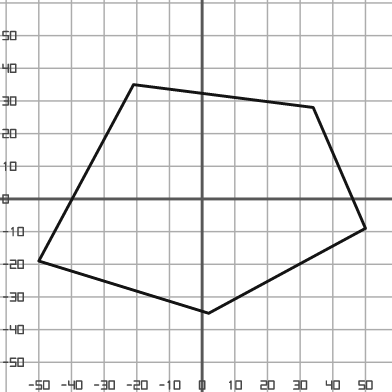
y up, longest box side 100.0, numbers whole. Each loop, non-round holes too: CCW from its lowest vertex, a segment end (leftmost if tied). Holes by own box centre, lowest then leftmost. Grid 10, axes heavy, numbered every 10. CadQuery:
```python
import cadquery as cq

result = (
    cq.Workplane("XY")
    .moveTo(2.0, -35.0)
    .lineTo(50.0, -9.0)
    .lineTo(34.0, 28.0)
    .lineTo(-21.0, 35.0)
    .lineTo(-50.0, -19.0)
    .close()
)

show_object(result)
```